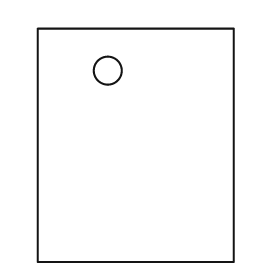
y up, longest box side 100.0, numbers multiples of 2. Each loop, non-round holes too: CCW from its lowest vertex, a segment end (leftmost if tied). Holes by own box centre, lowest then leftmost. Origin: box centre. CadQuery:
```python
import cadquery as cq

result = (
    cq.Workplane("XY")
    .moveTo(-42.0, -50.0)
    .lineTo(42.0, -50.0)
    .lineTo(42.0, 50.0)
    .lineTo(-42.0, 50.0)
    .close()
    .moveTo(-12.0, 32.0)
    .circle(6.0)
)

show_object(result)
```